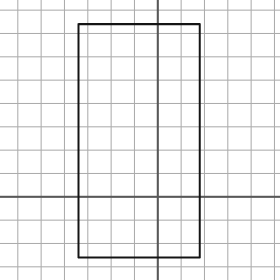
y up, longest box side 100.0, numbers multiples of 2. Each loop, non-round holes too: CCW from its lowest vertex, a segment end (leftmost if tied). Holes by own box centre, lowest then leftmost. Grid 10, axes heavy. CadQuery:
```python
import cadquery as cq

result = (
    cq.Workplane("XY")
    .moveTo(-34.0, -26.0)
    .lineTo(18.0, -26.0)
    .lineTo(18.0, 74.0)
    .lineTo(-34.0, 74.0)
    .close()
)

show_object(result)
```